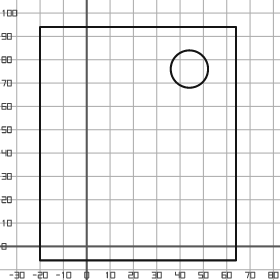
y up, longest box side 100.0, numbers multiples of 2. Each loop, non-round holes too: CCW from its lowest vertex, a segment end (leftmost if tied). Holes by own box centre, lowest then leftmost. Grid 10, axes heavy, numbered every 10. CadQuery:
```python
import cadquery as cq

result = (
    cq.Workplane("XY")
    .moveTo(-20.0, -6.0)
    .lineTo(64.0, -6.0)
    .lineTo(64.0, 94.0)
    .lineTo(-20.0, 94.0)
    .close()
    .moveTo(44.0, 76.0)
    .circle(8.0)
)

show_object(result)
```